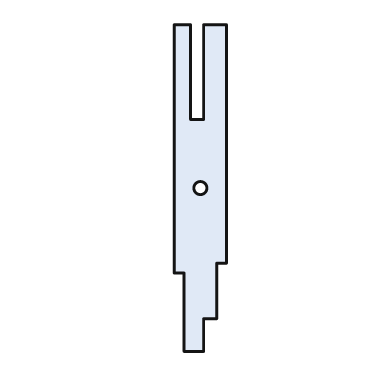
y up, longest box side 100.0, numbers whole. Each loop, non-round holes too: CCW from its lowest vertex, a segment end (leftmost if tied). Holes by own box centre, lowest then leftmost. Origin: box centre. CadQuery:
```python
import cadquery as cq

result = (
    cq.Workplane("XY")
    .moveTo(-5.0, -50.0)
    .lineTo(1.0, -50.0)
    .lineTo(1.0, -40.0)
    .lineTo(5.0, -40.0)
    .lineTo(5.0, -23.0)
    .lineTo(8.0, -23.0)
    .lineTo(8.0, 50.0)
    .lineTo(1.0, 50.0)
    .lineTo(1.0, 21.0)
    .lineTo(-3.0, 21.0)
    .lineTo(-3.0, 50.0)
    .lineTo(-8.0, 50.0)
    .lineTo(-8.0, -26.0)
    .lineTo(-5.0, -26.0)
    .close()
    .moveTo(0.0, 0.0)
    .circle(2.0)
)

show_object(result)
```